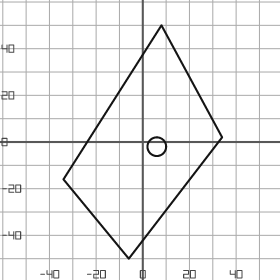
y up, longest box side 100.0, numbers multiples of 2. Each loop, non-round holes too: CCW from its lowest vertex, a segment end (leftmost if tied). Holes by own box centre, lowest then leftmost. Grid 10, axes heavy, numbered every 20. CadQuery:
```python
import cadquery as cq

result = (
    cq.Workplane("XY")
    .moveTo(-6.0, -50.0)
    .lineTo(34.0, 2.0)
    .lineTo(8.0, 50.0)
    .lineTo(-34.0, -16.0)
    .close()
    .moveTo(6.0, -2.0)
    .circle(4.0)
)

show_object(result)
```